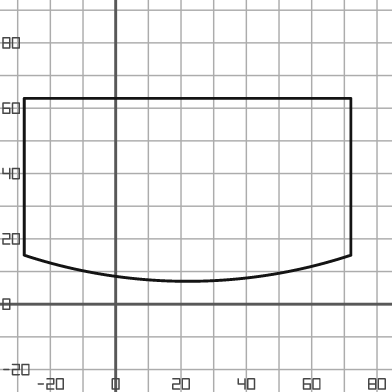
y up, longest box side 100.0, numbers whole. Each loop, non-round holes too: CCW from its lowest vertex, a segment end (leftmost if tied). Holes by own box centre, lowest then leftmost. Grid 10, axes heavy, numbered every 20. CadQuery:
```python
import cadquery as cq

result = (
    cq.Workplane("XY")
    .moveTo(-28.0, 15.0)
    .threePointArc((22.0, 7.0), (72.0, 15.0))
    .lineTo(72.0, 63.0)
    .lineTo(-28.0, 63.0)
    .close()
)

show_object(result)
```